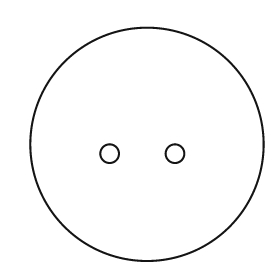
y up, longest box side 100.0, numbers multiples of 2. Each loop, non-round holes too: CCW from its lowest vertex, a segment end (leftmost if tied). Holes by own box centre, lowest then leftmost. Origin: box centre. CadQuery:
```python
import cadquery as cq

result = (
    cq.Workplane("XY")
    .moveTo(0.0, 0.0)
    .circle(50.0)
    .moveTo(-16.0, -4.0)
    .circle(4.0)
    .moveTo(12.0, -4.0)
    .circle(4.0)
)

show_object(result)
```